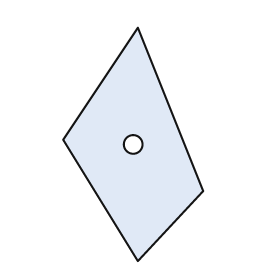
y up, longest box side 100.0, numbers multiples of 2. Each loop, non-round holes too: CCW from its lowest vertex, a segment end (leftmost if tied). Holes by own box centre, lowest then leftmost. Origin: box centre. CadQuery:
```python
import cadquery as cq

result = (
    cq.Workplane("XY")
    .moveTo(2.0, -50.0)
    .lineTo(30.0, -20.0)
    .lineTo(2.0, 50.0)
    .lineTo(-30.0, 2.0)
    .close()
    .moveTo(0.0, 0.0)
    .circle(4.0)
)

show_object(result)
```